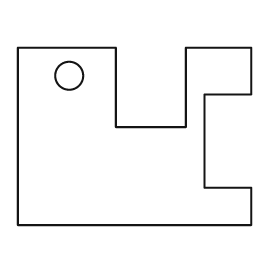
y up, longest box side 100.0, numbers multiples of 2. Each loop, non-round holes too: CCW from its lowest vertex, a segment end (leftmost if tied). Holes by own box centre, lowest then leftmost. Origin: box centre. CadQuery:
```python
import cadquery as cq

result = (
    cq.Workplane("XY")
    .moveTo(-50.0, -38.0)
    .lineTo(50.0, -38.0)
    .lineTo(50.0, -22.0)
    .lineTo(30.0, -22.0)
    .lineTo(30.0, 18.0)
    .lineTo(50.0, 18.0)
    .lineTo(50.0, 38.0)
    .lineTo(22.0, 38.0)
    .lineTo(22.0, 4.0)
    .lineTo(-8.0, 4.0)
    .lineTo(-8.0, 38.0)
    .lineTo(-50.0, 38.0)
    .close()
    .moveTo(-28.0, 26.0)
    .circle(6.0)
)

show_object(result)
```